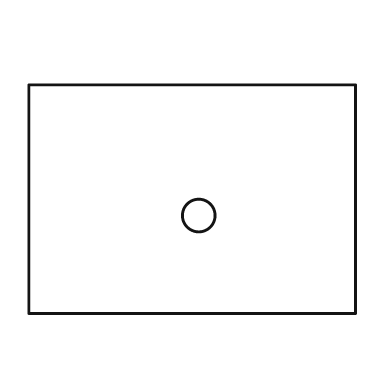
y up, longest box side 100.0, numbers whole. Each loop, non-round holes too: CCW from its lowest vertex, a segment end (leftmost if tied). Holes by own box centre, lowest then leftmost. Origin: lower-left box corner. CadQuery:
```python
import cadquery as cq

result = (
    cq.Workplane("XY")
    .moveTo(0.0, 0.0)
    .lineTo(100.0, 0.0)
    .lineTo(100.0, 70.0)
    .lineTo(0.0, 70.0)
    .close()
    .moveTo(52.0, 30.0)
    .circle(5.0)
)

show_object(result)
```